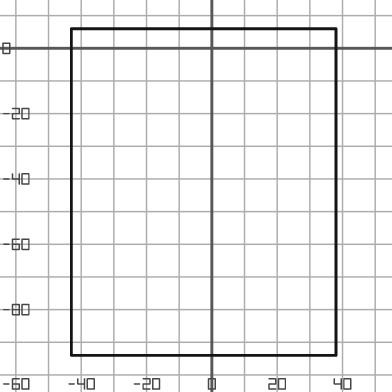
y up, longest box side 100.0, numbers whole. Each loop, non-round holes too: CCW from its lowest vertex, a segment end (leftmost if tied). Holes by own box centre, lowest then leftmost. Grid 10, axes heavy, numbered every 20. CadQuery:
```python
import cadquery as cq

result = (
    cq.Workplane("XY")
    .moveTo(-43.0, -94.0)
    .lineTo(38.0, -94.0)
    .lineTo(38.0, 6.0)
    .lineTo(-43.0, 6.0)
    .close()
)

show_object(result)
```